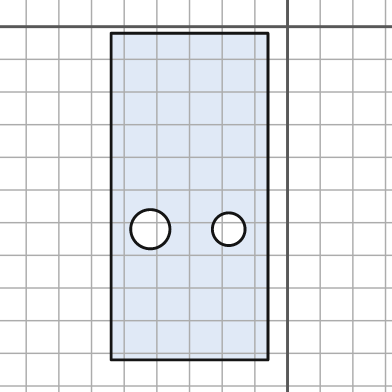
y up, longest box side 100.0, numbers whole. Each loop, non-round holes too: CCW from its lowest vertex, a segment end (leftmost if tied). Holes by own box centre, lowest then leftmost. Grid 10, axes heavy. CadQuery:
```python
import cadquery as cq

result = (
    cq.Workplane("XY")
    .moveTo(-54.0, -102.0)
    .lineTo(-6.0, -102.0)
    .lineTo(-6.0, -2.0)
    .lineTo(-54.0, -2.0)
    .close()
    .moveTo(-42.0, -62.0)
    .circle(6.0)
    .moveTo(-18.0, -62.0)
    .circle(5.0)
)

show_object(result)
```